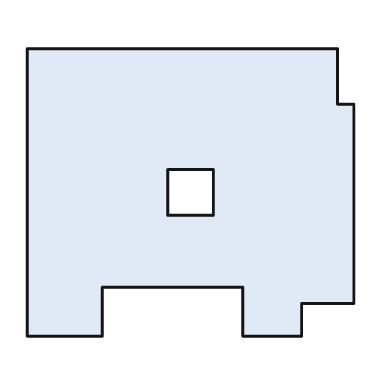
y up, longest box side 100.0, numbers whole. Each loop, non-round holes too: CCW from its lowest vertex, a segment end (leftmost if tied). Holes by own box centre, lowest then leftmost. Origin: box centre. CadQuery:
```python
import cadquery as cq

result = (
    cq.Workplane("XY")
    .moveTo(-50.0, -44.0)
    .lineTo(-27.0, -44.0)
    .lineTo(-27.0, -29.0)
    .lineTo(16.0, -29.0)
    .lineTo(16.0, -44.0)
    .lineTo(34.0, -44.0)
    .lineTo(34.0, -34.0)
    .lineTo(50.0, -34.0)
    .lineTo(50.0, 27.0)
    .lineTo(45.0, 27.0)
    .lineTo(45.0, 44.0)
    .lineTo(-50.0, 44.0)
    .close()
    .moveTo(-7.0, -7.0)
    .lineTo(7.0, -7.0)
    .lineTo(7.0, 7.0)
    .lineTo(-7.0, 7.0)
    .close()
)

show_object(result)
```